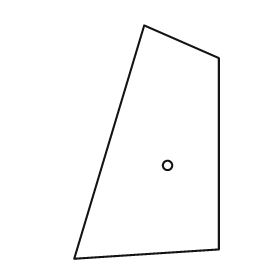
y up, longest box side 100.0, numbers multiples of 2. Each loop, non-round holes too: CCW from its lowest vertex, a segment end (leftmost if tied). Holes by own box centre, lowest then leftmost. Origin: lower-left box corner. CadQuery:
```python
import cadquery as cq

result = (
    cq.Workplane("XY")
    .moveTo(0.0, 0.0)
    .lineTo(62.0, 4.0)
    .lineTo(62.0, 86.0)
    .lineTo(30.0, 100.0)
    .close()
    .moveTo(40.0, 40.0)
    .circle(2.0)
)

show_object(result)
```